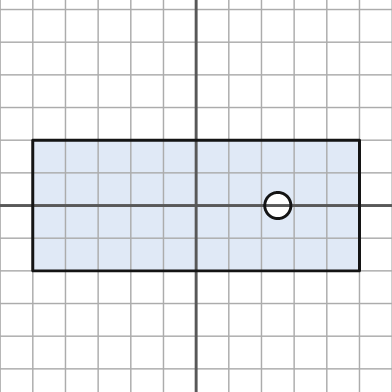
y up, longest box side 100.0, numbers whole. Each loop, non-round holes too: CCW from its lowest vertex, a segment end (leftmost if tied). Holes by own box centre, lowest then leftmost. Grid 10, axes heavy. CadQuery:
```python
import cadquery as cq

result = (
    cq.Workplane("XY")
    .moveTo(-50.0, -20.0)
    .lineTo(50.0, -20.0)
    .lineTo(50.0, 20.0)
    .lineTo(-50.0, 20.0)
    .close()
    .moveTo(25.0, 0.0)
    .circle(4.0)
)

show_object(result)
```